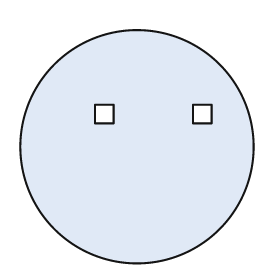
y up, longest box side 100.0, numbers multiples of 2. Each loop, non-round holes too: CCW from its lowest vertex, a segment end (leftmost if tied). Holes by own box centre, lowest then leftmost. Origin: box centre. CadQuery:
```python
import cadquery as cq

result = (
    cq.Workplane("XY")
    .moveTo(0.0, 0.0)
    .circle(50.0)
    .moveTo(-18.0, 10.0)
    .lineTo(-10.0, 10.0)
    .lineTo(-10.0, 18.0)
    .lineTo(-18.0, 18.0)
    .close()
    .moveTo(24.0, 10.0)
    .lineTo(32.0, 10.0)
    .lineTo(32.0, 18.0)
    .lineTo(24.0, 18.0)
    .close()
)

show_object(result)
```